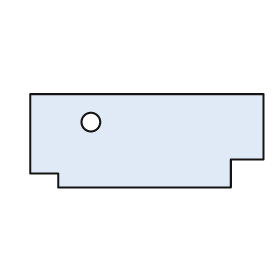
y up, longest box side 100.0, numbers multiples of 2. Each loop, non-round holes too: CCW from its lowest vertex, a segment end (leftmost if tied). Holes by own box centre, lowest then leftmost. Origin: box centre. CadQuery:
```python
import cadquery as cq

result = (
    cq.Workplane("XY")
    .moveTo(-38.0, -20.0)
    .lineTo(36.0, -20.0)
    .lineTo(36.0, -8.0)
    .lineTo(50.0, -8.0)
    .lineTo(50.0, 20.0)
    .lineTo(-50.0, 20.0)
    .lineTo(-50.0, -14.0)
    .lineTo(-38.0, -14.0)
    .close()
    .moveTo(-24.0, 8.0)
    .circle(4.0)
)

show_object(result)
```